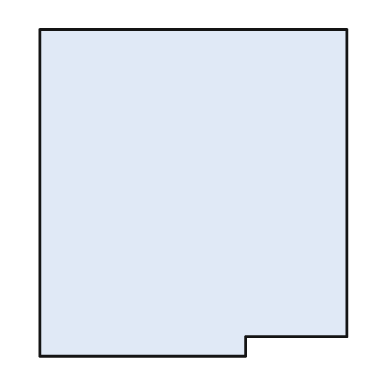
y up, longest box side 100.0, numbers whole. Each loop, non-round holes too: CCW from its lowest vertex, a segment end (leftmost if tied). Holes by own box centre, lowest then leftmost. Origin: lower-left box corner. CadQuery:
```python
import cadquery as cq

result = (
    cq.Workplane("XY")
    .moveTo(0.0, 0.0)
    .lineTo(63.0, 0.0)
    .lineTo(63.0, 6.0)
    .lineTo(94.0, 6.0)
    .lineTo(94.0, 100.0)
    .lineTo(0.0, 100.0)
    .close()
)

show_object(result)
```